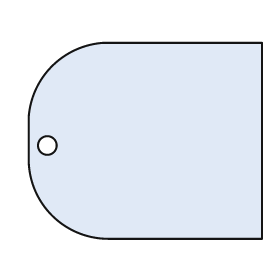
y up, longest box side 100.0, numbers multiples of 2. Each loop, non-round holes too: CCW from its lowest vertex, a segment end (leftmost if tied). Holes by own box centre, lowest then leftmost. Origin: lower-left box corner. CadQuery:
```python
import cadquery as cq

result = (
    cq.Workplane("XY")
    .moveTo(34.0, 0.0)
    .lineTo(100.0, 0.0)
    .lineTo(100.0, 84.0)
    .lineTo(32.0, 84.0)
    .threePointArc((10.0, 74.0), (0.0, 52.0))
    .lineTo(0.0, 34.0)
    .threePointArc((10.0, 10.0), (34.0, 0.0))
    .close()
    .moveTo(8.0, 40.0)
    .circle(4.0)
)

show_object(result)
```